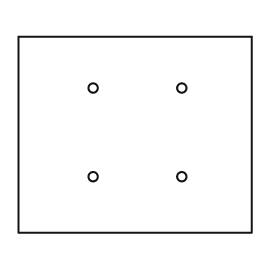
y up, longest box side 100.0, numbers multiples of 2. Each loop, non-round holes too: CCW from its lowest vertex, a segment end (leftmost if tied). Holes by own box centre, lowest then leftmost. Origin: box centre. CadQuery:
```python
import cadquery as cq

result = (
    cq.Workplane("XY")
    .moveTo(-50.0, -42.0)
    .lineTo(50.0, -42.0)
    .lineTo(50.0, 42.0)
    .lineTo(-50.0, 42.0)
    .close()
    .moveTo(-18.0, -18.0)
    .circle(2.0)
    .moveTo(20.0, -18.0)
    .circle(2.0)
    .moveTo(-18.0, 20.0)
    .circle(2.0)
    .moveTo(20.0, 20.0)
    .circle(2.0)
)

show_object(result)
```